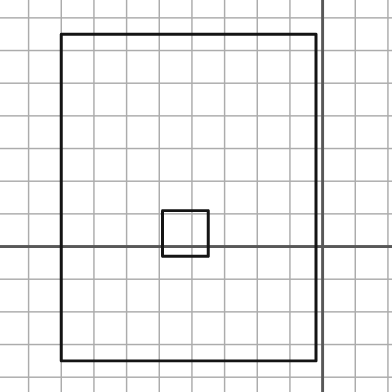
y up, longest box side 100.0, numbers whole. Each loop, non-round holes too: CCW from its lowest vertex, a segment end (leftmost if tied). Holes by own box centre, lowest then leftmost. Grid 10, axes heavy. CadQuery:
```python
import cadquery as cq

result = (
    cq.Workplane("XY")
    .moveTo(-80.0, -35.0)
    .lineTo(-2.0, -35.0)
    .lineTo(-2.0, 65.0)
    .lineTo(-80.0, 65.0)
    .close()
    .moveTo(-49.0, -3.0)
    .lineTo(-35.0, -3.0)
    .lineTo(-35.0, 11.0)
    .lineTo(-49.0, 11.0)
    .close()
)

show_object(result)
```